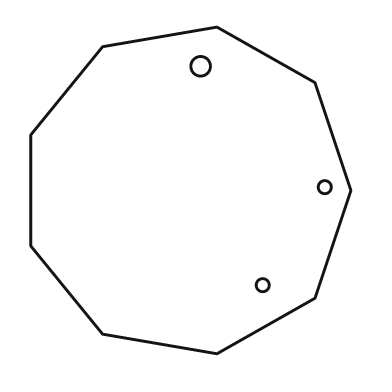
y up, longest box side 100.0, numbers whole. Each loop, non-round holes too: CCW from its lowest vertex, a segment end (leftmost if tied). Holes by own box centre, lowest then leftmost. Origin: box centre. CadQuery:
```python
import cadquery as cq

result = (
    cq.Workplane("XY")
    .moveTo(8.0, -50.0)
    .lineTo(38.0, -33.0)
    .lineTo(49.0, 0.0)
    .lineTo(38.0, 33.0)
    .lineTo(8.0, 50.0)
    .lineTo(-27.0, 44.0)
    .lineTo(-49.0, 17.0)
    .lineTo(-49.0, -17.0)
    .lineTo(-27.0, -44.0)
    .close()
    .moveTo(22.0, -29.0)
    .circle(2.0)
    .moveTo(41.0, 1.0)
    .circle(2.0)
    .moveTo(3.0, 38.0)
    .circle(3.0)
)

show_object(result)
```